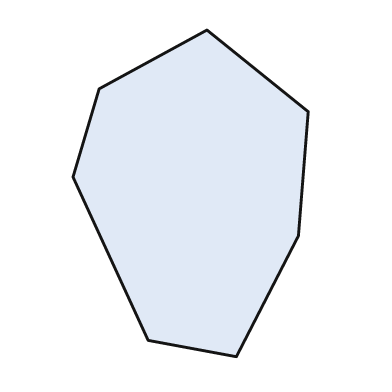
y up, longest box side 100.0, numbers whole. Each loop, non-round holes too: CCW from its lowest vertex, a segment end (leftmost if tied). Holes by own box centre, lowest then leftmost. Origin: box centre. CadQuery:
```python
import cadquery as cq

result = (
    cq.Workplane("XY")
    .moveTo(14.0, -50.0)
    .lineTo(33.0, -13.0)
    .lineTo(36.0, 25.0)
    .lineTo(5.0, 50.0)
    .lineTo(-28.0, 32.0)
    .lineTo(-36.0, 5.0)
    .lineTo(-13.0, -45.0)
    .close()
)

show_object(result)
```